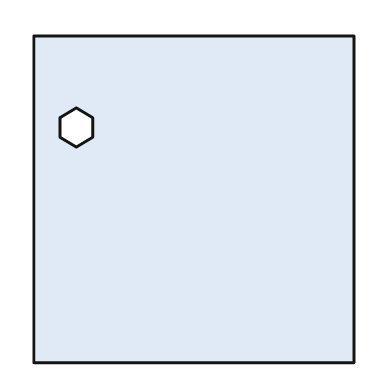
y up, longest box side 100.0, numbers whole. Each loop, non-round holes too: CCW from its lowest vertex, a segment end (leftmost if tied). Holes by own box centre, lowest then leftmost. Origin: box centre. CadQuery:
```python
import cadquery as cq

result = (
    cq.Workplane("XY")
    .moveTo(-49.0, -50.0)
    .lineTo(49.0, -50.0)
    .lineTo(49.0, 50.0)
    .lineTo(-49.0, 50.0)
    .close()
    .moveTo(-36.0, 16.0)
    .lineTo(-31.0, 19.0)
    .lineTo(-31.0, 25.0)
    .lineTo(-36.0, 28.0)
    .lineTo(-41.0, 25.0)
    .lineTo(-41.0, 19.0)
    .close()
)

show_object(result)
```